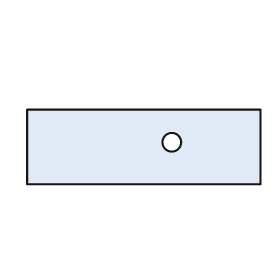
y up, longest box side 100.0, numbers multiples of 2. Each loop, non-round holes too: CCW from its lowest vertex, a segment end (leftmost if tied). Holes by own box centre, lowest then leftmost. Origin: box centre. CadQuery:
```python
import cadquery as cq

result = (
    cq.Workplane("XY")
    .moveTo(-50.0, -16.0)
    .lineTo(50.0, -16.0)
    .lineTo(50.0, 16.0)
    .lineTo(-50.0, 16.0)
    .close()
    .moveTo(12.0, 2.0)
    .circle(4.0)
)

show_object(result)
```